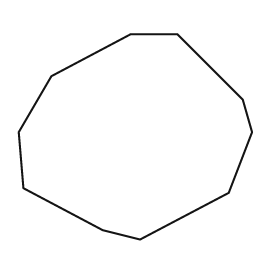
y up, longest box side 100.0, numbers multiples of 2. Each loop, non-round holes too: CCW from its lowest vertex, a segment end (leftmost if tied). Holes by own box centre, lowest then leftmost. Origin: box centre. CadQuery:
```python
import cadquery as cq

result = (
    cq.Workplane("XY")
    .moveTo(2.0, -44.0)
    .lineTo(40.0, -24.0)
    .lineTo(50.0, 2.0)
    .lineTo(46.0, 16.0)
    .lineTo(18.0, 44.0)
    .lineTo(-2.0, 44.0)
    .lineTo(-36.0, 26.0)
    .lineTo(-50.0, 2.0)
    .lineTo(-48.0, -22.0)
    .lineTo(-14.0, -40.0)
    .close()
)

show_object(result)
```